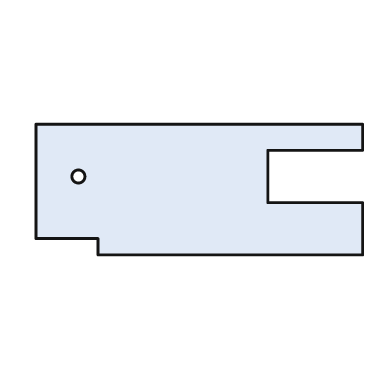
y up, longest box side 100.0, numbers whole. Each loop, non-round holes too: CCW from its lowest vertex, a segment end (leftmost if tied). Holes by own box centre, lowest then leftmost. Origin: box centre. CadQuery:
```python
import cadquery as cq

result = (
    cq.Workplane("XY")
    .moveTo(-31.0, -20.0)
    .lineTo(50.0, -20.0)
    .lineTo(50.0, -4.0)
    .lineTo(21.0, -4.0)
    .lineTo(21.0, 12.0)
    .lineTo(50.0, 12.0)
    .lineTo(50.0, 20.0)
    .lineTo(-50.0, 20.0)
    .lineTo(-50.0, -15.0)
    .lineTo(-31.0, -15.0)
    .close()
    .moveTo(-37.0, 4.0)
    .circle(2.0)
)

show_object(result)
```